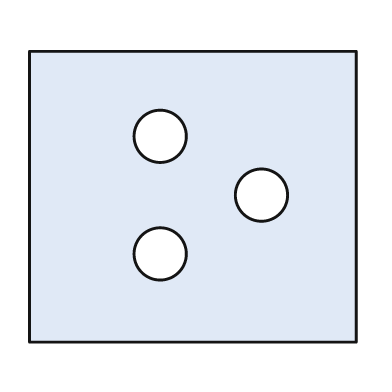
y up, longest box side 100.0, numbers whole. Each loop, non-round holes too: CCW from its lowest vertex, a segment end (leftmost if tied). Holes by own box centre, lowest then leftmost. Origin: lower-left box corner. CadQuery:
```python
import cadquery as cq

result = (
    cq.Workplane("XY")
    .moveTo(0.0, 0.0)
    .lineTo(100.0, 0.0)
    .lineTo(100.0, 89.0)
    .lineTo(0.0, 89.0)
    .close()
    .moveTo(40.0, 27.0)
    .circle(8.0)
    .moveTo(71.0, 45.0)
    .circle(8.0)
    .moveTo(40.0, 63.0)
    .circle(8.0)
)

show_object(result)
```